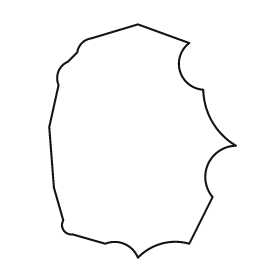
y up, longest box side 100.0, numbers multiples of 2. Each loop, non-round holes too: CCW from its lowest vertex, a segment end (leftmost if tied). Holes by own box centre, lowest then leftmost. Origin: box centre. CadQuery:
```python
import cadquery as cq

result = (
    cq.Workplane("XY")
    .moveTo(-2.0, -50.0)
    .threePointArc((8.0, -44.0), (20.0, -44.0))
    .lineTo(30.0, -24.0)
    .threePointArc((28.0, -10.0), (40.0, -2.0))
    .threePointArc((30.0, 8.0), (26.0, 22.0))
    .threePointArc((16.0, 30.0), (20.0, 42.0))
    .lineTo(-2.0, 50.0)
    .lineTo(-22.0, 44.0)
    .threePointArc((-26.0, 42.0), (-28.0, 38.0))
    .lineTo(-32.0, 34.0)
    .threePointArc((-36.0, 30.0), (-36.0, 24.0))
    .lineTo(-40.0, 6.0)
    .lineTo(-38.0, -20.0)
    .lineTo(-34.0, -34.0)
    .threePointArc((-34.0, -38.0), (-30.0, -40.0))
    .lineTo(-16.0, -44.0)
    .threePointArc((-8.0, -44.0), (-2.0, -50.0))
    .close()
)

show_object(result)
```